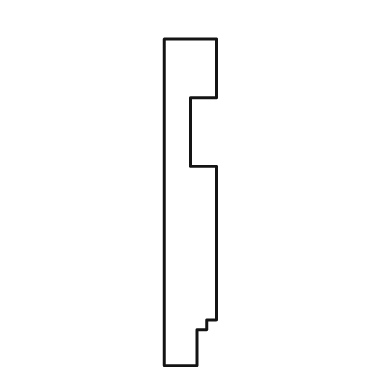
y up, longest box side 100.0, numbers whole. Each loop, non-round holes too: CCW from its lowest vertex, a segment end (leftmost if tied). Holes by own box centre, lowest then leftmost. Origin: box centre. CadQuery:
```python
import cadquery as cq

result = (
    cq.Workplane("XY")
    .moveTo(-8.0, -50.0)
    .lineTo(2.0, -50.0)
    .lineTo(2.0, -39.0)
    .lineTo(5.0, -39.0)
    .lineTo(5.0, -36.0)
    .lineTo(8.0, -36.0)
    .lineTo(8.0, 11.0)
    .lineTo(0.0, 11.0)
    .lineTo(0.0, 32.0)
    .lineTo(8.0, 32.0)
    .lineTo(8.0, 50.0)
    .lineTo(-8.0, 50.0)
    .close()
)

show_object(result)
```